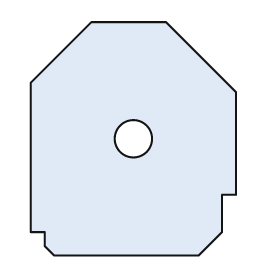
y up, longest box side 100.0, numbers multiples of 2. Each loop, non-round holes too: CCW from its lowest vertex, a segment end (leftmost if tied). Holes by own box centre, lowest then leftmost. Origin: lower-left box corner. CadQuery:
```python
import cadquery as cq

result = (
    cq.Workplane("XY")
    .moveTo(10.0, 0.0)
    .lineTo(72.0, 0.0)
    .lineTo(82.0, 10.0)
    .lineTo(82.0, 26.0)
    .lineTo(88.0, 26.0)
    .lineTo(88.0, 70.0)
    .lineTo(58.0, 100.0)
    .lineTo(26.0, 100.0)
    .lineTo(0.0, 74.0)
    .lineTo(0.0, 10.0)
    .lineTo(6.0, 10.0)
    .lineTo(6.0, 4.0)
    .close()
    .moveTo(44.0, 50.0)
    .circle(8.0)
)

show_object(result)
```